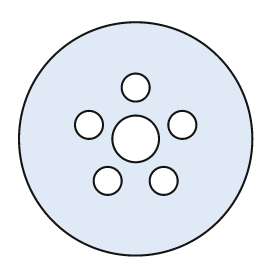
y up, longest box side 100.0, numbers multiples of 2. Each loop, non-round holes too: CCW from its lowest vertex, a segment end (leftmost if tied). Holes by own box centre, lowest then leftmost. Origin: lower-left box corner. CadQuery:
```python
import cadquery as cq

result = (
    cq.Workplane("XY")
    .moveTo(50.0, 50.0)
    .circle(50.0)
    .moveTo(38.0, 32.0)
    .circle(6.0)
    .moveTo(62.0, 32.0)
    .circle(6.0)
    .moveTo(50.0, 50.0)
    .circle(10.0)
    .moveTo(30.0, 56.0)
    .circle(6.0)
    .moveTo(70.0, 56.0)
    .circle(6.0)
    .moveTo(50.0, 72.0)
    .circle(6.0)
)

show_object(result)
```